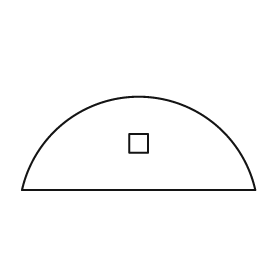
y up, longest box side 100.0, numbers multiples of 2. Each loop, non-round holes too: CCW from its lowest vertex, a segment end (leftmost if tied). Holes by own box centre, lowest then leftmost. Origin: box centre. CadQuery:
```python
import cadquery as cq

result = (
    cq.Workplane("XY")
    .moveTo(-50.0, -20.0)
    .lineTo(50.0, -20.0)
    .threePointArc((0.0, 20.0), (-50.0, -20.0))
    .close()
    .moveTo(-4.0, -4.0)
    .lineTo(4.0, -4.0)
    .lineTo(4.0, 4.0)
    .lineTo(-4.0, 4.0)
    .close()
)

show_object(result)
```